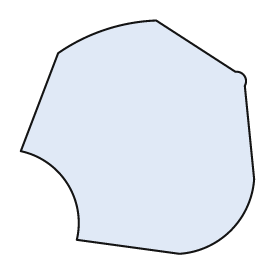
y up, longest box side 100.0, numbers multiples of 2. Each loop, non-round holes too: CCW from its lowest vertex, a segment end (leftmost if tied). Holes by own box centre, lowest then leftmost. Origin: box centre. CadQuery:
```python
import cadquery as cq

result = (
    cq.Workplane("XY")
    .moveTo(18.0, -50.0)
    .threePointArc((40.0, -40.0), (50.0, -18.0))
    .lineTo(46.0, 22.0)
    .threePointArc((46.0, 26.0), (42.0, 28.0))
    .lineTo(8.0, 50.0)
    .threePointArc((-14.0, 46.0), (-34.0, 36.0))
    .lineTo(-50.0, -6.0)
    .threePointArc((-30.0, -20.0), (-26.0, -44.0))
    .close()
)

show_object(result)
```